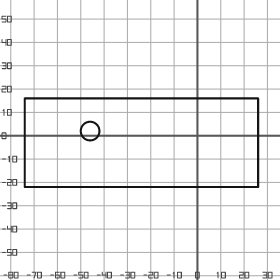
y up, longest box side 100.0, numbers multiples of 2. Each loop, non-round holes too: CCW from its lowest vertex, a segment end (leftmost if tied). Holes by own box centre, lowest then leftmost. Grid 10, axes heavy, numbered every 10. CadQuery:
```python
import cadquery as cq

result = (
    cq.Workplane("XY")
    .moveTo(-74.0, -22.0)
    .lineTo(26.0, -22.0)
    .lineTo(26.0, 16.0)
    .lineTo(-74.0, 16.0)
    .close()
    .moveTo(-46.0, 2.0)
    .circle(4.0)
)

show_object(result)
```